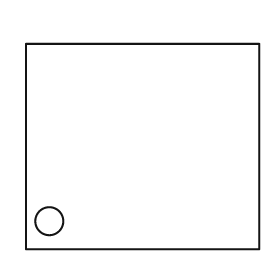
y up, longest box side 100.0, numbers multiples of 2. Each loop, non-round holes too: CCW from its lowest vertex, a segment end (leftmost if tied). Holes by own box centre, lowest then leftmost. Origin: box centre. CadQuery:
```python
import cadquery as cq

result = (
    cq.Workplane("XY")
    .moveTo(-50.0, -44.0)
    .lineTo(50.0, -44.0)
    .lineTo(50.0, 44.0)
    .lineTo(-50.0, 44.0)
    .close()
    .moveTo(-40.0, -32.0)
    .circle(6.0)
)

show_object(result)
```